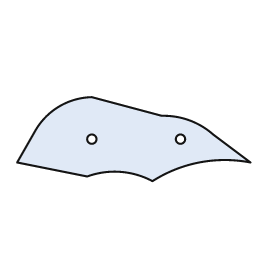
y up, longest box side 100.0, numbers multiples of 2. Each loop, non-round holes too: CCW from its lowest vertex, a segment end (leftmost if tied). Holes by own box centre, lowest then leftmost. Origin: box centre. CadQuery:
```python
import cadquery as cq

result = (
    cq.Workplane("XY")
    .moveTo(8.0, -18.0)
    .threePointArc((28.0, -10.0), (50.0, -10.0))
    .lineTo(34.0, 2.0)
    .threePointArc((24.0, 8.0), (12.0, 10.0))
    .lineTo(-18.0, 18.0)
    .threePointArc((-32.0, 14.0), (-42.0, 4.0))
    .lineTo(-50.0, -10.0)
    .lineTo(-20.0, -16.0)
    .threePointArc((-6.0, -14.0), (8.0, -18.0))
    .close()
    .moveTo(-18.0, 0.0)
    .circle(2.0)
    .moveTo(20.0, 0.0)
    .circle(2.0)
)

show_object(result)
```